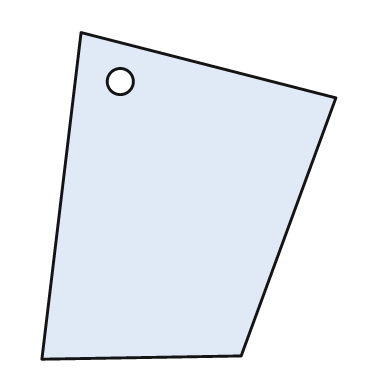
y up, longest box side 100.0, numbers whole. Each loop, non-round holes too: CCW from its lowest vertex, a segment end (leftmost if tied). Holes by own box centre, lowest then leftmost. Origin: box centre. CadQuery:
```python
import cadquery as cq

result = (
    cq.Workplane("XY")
    .moveTo(-45.0, -50.0)
    .lineTo(16.0, -49.0)
    .lineTo(45.0, 30.0)
    .lineTo(-33.0, 50.0)
    .close()
    .moveTo(-21.0, 35.0)
    .circle(4.0)
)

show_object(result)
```